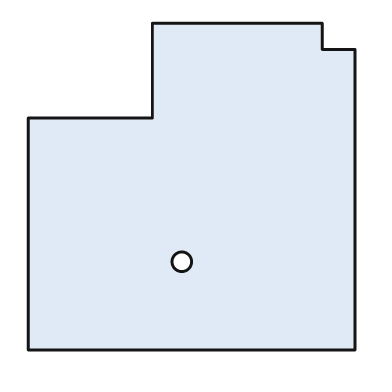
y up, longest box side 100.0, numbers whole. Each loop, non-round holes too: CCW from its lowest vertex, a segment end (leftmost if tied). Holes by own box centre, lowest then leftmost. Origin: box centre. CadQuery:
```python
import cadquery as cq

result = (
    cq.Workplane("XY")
    .moveTo(-50.0, -50.0)
    .lineTo(50.0, -50.0)
    .lineTo(50.0, 42.0)
    .lineTo(40.0, 42.0)
    .lineTo(40.0, 50.0)
    .lineTo(-12.0, 50.0)
    .lineTo(-12.0, 21.0)
    .lineTo(-50.0, 21.0)
    .close()
    .moveTo(-3.0, -23.0)
    .circle(3.0)
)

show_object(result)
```